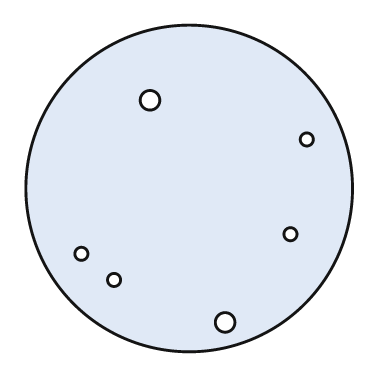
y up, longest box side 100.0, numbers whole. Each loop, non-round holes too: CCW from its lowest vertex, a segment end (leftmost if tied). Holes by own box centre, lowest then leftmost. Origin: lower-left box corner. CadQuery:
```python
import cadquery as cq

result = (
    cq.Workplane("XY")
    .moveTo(50.0, 50.0)
    .circle(50.0)
    .moveTo(61.0, 9.0)
    .circle(3.0)
    .moveTo(27.0, 22.0)
    .circle(2.0)
    .moveTo(17.0, 30.0)
    .circle(2.0)
    .moveTo(81.0, 36.0)
    .circle(2.0)
    .moveTo(86.0, 65.0)
    .circle(2.0)
    .moveTo(38.0, 77.0)
    .circle(3.0)
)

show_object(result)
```